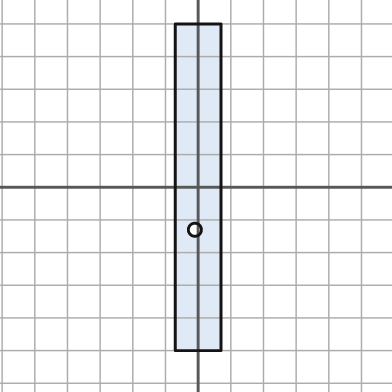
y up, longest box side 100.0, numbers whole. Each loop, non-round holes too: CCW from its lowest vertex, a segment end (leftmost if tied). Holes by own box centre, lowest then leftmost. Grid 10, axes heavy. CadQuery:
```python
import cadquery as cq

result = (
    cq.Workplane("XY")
    .moveTo(-7.0, -50.0)
    .lineTo(7.0, -50.0)
    .lineTo(7.0, 50.0)
    .lineTo(-7.0, 50.0)
    .close()
    .moveTo(-1.0, -13.0)
    .circle(2.0)
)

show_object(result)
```